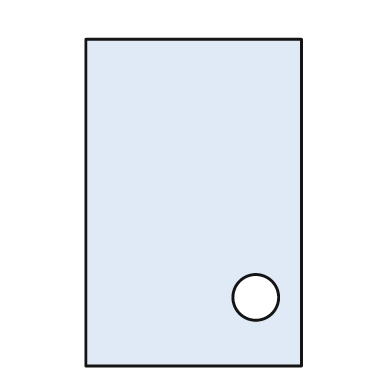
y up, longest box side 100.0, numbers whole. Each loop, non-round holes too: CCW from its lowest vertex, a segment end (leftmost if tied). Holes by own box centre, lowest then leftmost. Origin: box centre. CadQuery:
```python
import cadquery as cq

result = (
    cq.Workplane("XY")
    .moveTo(-33.0, -50.0)
    .lineTo(33.0, -50.0)
    .lineTo(33.0, 50.0)
    .lineTo(-33.0, 50.0)
    .close()
    .moveTo(19.0, -29.0)
    .circle(7.0)
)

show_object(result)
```